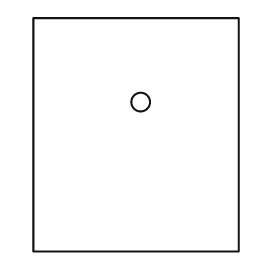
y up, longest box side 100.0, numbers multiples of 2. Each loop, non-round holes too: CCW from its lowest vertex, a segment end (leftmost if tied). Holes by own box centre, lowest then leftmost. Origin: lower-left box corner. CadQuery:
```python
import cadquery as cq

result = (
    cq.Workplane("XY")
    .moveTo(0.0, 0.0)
    .lineTo(88.0, 0.0)
    .lineTo(88.0, 100.0)
    .lineTo(0.0, 100.0)
    .close()
    .moveTo(46.0, 64.0)
    .circle(4.0)
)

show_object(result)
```